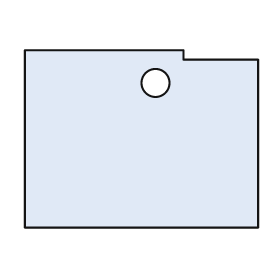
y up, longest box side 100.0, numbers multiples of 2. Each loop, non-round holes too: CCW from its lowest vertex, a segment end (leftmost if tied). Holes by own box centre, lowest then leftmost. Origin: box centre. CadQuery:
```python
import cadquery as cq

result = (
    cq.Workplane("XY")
    .moveTo(-50.0, -38.0)
    .lineTo(50.0, -38.0)
    .lineTo(50.0, 34.0)
    .lineTo(18.0, 34.0)
    .lineTo(18.0, 38.0)
    .lineTo(-50.0, 38.0)
    .close()
    .moveTo(6.0, 24.0)
    .circle(6.0)
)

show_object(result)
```